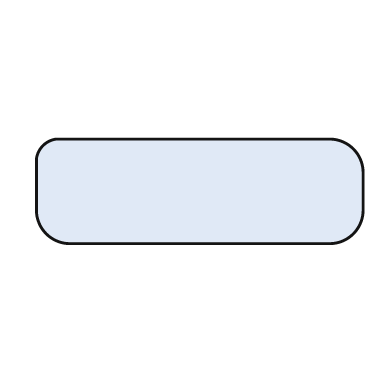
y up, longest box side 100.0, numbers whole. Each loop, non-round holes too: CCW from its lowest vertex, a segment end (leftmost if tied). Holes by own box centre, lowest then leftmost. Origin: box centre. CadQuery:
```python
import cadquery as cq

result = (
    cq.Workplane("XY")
    .moveTo(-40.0, -16.0)
    .lineTo(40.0, -16.0)
    .threePointArc((47.0, -13.0), (50.0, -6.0))
    .lineTo(50.0, 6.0)
    .threePointArc((47.0, 13.0), (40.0, 16.0))
    .lineTo(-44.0, 16.0)
    .threePointArc((-48.0, 14.0), (-50.0, 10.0))
    .lineTo(-50.0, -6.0)
    .threePointArc((-47.0, -13.0), (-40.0, -16.0))
    .close()
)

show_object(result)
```